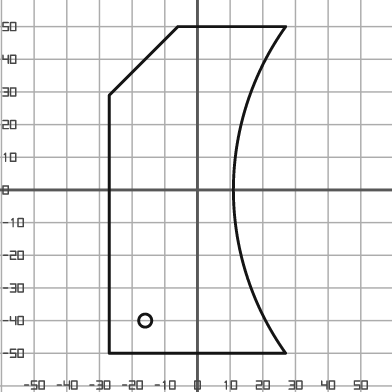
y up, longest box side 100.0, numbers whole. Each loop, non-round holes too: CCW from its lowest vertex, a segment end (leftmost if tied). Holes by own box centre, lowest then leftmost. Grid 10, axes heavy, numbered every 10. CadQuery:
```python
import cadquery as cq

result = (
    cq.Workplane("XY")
    .moveTo(-27.0, -50.0)
    .lineTo(27.0, -50.0)
    .threePointArc((11.0, 0.0), (27.0, 50.0))
    .lineTo(-6.0, 50.0)
    .lineTo(-27.0, 29.0)
    .close()
    .moveTo(-16.0, -40.0)
    .circle(2.0)
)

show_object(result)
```